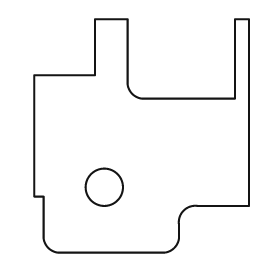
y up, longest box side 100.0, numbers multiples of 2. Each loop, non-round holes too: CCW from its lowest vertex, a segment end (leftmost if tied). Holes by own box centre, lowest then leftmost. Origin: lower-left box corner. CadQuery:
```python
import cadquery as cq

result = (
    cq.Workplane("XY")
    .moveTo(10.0, 0.0)
    .lineTo(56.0, 0.0)
    .threePointArc((60.0, 2.0), (62.0, 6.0))
    .lineTo(62.0, 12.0)
    .threePointArc((64.0, 18.0), (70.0, 20.0))
    .lineTo(92.0, 20.0)
    .lineTo(92.0, 100.0)
    .lineTo(86.0, 100.0)
    .lineTo(86.0, 66.0)
    .lineTo(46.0, 66.0)
    .threePointArc((42.0, 68.0), (40.0, 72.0))
    .lineTo(40.0, 100.0)
    .lineTo(26.0, 100.0)
    .lineTo(26.0, 76.0)
    .lineTo(0.0, 76.0)
    .lineTo(0.0, 24.0)
    .lineTo(4.0, 24.0)
    .lineTo(4.0, 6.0)
    .threePointArc((6.0, 2.0), (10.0, 0.0))
    .close()
    .moveTo(30.0, 28.0)
    .circle(8.0)
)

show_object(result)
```